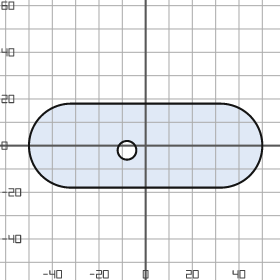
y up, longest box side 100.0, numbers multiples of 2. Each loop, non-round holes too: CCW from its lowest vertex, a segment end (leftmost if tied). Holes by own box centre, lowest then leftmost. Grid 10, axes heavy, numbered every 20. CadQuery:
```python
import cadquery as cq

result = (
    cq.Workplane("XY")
    .moveTo(-32.0, -18.0)
    .lineTo(32.0, -18.0)
    .threePointArc((50.0, 0.0), (32.0, 18.0))
    .lineTo(-32.0, 18.0)
    .threePointArc((-50.0, 0.0), (-32.0, -18.0))
    .close()
    .moveTo(-8.0, -2.0)
    .circle(4.0)
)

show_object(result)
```